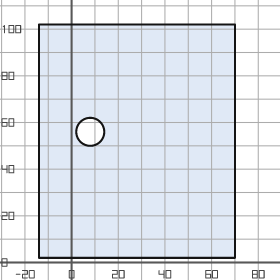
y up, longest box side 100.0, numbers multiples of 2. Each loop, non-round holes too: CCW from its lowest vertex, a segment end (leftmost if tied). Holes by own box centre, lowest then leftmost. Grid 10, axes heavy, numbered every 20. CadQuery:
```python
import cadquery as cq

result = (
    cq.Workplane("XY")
    .moveTo(-14.0, 2.0)
    .lineTo(70.0, 2.0)
    .lineTo(70.0, 102.0)
    .lineTo(-14.0, 102.0)
    .close()
    .moveTo(8.0, 56.0)
    .circle(6.0)
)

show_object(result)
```